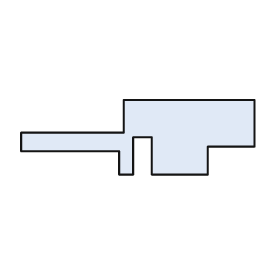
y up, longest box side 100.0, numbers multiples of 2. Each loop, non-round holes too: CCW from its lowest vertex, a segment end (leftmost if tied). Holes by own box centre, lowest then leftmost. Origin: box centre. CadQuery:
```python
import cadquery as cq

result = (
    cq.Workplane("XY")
    .moveTo(-8.0, -16.0)
    .lineTo(-2.0, -16.0)
    .lineTo(-2.0, 0.0)
    .lineTo(6.0, 0.0)
    .lineTo(6.0, -16.0)
    .lineTo(30.0, -16.0)
    .lineTo(30.0, -4.0)
    .lineTo(50.0, -4.0)
    .lineTo(50.0, 16.0)
    .lineTo(-6.0, 16.0)
    .lineTo(-6.0, 2.0)
    .lineTo(-50.0, 2.0)
    .lineTo(-50.0, -6.0)
    .lineTo(-8.0, -6.0)
    .close()
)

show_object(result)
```